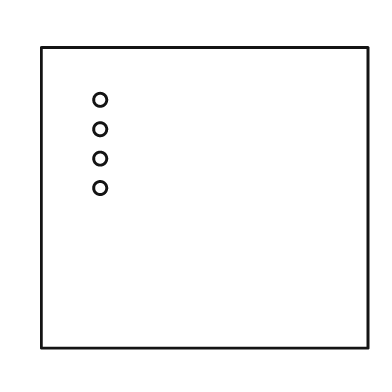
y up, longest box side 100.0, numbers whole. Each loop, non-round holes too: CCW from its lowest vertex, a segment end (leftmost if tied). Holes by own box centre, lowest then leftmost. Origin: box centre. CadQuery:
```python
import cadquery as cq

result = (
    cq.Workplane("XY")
    .moveTo(-50.0, -46.0)
    .lineTo(50.0, -46.0)
    .lineTo(50.0, 46.0)
    .lineTo(-50.0, 46.0)
    .close()
    .moveTo(-32.0, 3.0)
    .circle(2.0)
    .moveTo(-32.0, 12.0)
    .circle(2.0)
    .moveTo(-32.0, 21.0)
    .circle(2.0)
    .moveTo(-32.0, 30.0)
    .circle(2.0)
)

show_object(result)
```